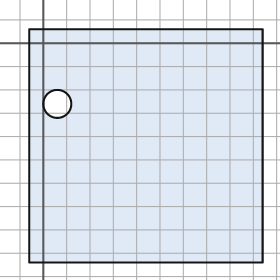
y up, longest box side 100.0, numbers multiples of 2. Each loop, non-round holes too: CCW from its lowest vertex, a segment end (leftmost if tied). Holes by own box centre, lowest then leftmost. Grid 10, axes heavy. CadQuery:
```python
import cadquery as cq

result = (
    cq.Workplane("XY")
    .moveTo(-6.0, -94.0)
    .lineTo(94.0, -94.0)
    .lineTo(94.0, 6.0)
    .lineTo(-6.0, 6.0)
    .close()
    .moveTo(6.0, -26.0)
    .circle(6.0)
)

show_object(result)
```